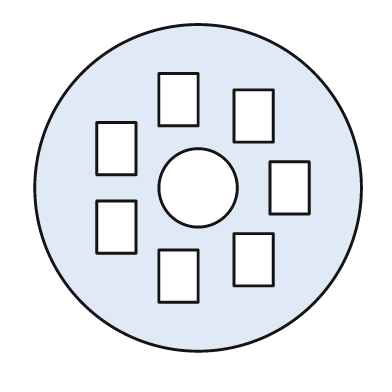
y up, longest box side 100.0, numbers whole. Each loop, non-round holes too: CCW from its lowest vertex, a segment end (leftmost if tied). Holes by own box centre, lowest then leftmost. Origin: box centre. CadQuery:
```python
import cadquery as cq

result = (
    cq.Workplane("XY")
    .moveTo(0.0, 0.0)
    .circle(50.0)
    .moveTo(-12.0, -35.0)
    .lineTo(0.0, -35.0)
    .lineTo(0.0, -19.0)
    .lineTo(-12.0, -19.0)
    .close()
    .moveTo(11.0, -30.0)
    .lineTo(23.0, -30.0)
    .lineTo(23.0, -14.0)
    .lineTo(11.0, -14.0)
    .close()
    .moveTo(-31.0, -20.0)
    .lineTo(-19.0, -20.0)
    .lineTo(-19.0, -4.0)
    .lineTo(-31.0, -4.0)
    .close()
    .moveTo(0.0, 0.0)
    .circle(12.0)
    .moveTo(22.0, -8.0)
    .lineTo(34.0, -8.0)
    .lineTo(34.0, 8.0)
    .lineTo(22.0, 8.0)
    .close()
    .moveTo(-31.0, 4.0)
    .lineTo(-19.0, 4.0)
    .lineTo(-19.0, 20.0)
    .lineTo(-31.0, 20.0)
    .close()
    .moveTo(11.0, 14.0)
    .lineTo(23.0, 14.0)
    .lineTo(23.0, 30.0)
    .lineTo(11.0, 30.0)
    .close()
    .moveTo(-12.0, 19.0)
    .lineTo(0.0, 19.0)
    .lineTo(0.0, 35.0)
    .lineTo(-12.0, 35.0)
    .close()
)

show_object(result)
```